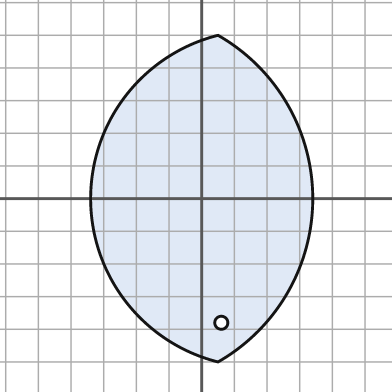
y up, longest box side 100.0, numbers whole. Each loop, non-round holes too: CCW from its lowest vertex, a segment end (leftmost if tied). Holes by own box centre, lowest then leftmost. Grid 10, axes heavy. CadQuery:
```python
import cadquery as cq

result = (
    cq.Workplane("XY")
    .moveTo(5.0, -50.0)
    .threePointArc((34.0, 0.0), (5.0, 50.0))
    .threePointArc((-34.0, 0.0), (5.0, -50.0))
    .close()
    .moveTo(6.0, -38.0)
    .circle(2.0)
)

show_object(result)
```